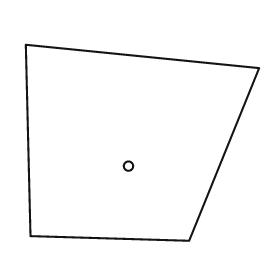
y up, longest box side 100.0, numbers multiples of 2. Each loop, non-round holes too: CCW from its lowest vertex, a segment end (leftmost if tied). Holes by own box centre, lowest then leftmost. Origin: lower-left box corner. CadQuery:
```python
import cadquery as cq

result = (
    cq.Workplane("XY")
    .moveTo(70.0, 0.0)
    .lineTo(100.0, 74.0)
    .lineTo(0.0, 84.0)
    .lineTo(2.0, 2.0)
    .close()
    .moveTo(44.0, 32.0)
    .circle(2.0)
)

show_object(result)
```